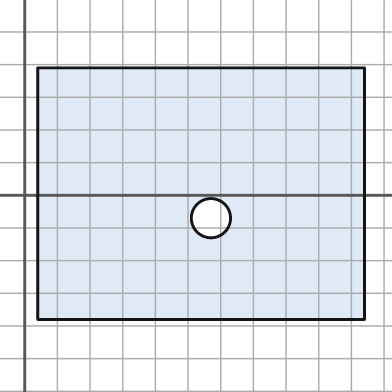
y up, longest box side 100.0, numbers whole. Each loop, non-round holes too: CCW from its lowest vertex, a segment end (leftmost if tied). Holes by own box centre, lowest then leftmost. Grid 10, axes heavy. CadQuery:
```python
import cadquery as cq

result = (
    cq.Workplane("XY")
    .moveTo(4.0, -38.0)
    .lineTo(104.0, -38.0)
    .lineTo(104.0, 39.0)
    .lineTo(4.0, 39.0)
    .close()
    .moveTo(57.0, -7.0)
    .circle(6.0)
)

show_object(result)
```